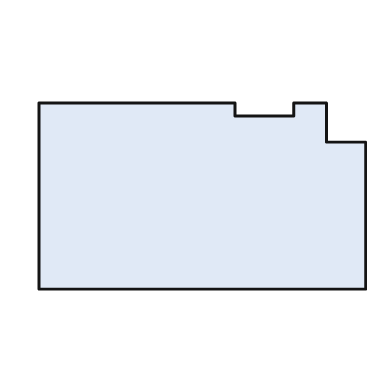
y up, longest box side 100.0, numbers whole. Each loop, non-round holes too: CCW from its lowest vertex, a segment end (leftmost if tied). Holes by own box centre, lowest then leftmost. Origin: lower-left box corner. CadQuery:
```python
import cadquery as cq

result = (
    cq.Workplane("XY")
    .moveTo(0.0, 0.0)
    .lineTo(100.0, 0.0)
    .lineTo(100.0, 45.0)
    .lineTo(88.0, 45.0)
    .lineTo(88.0, 57.0)
    .lineTo(78.0, 57.0)
    .lineTo(78.0, 53.0)
    .lineTo(60.0, 53.0)
    .lineTo(60.0, 57.0)
    .lineTo(0.0, 57.0)
    .close()
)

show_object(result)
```